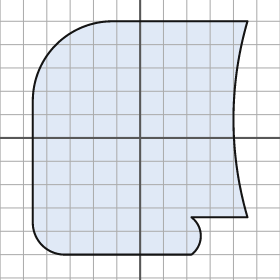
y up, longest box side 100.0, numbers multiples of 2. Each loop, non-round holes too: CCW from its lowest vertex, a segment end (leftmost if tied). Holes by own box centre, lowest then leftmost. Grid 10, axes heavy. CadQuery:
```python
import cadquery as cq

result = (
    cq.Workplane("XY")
    .moveTo(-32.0, -50.0)
    .lineTo(22.0, -50.0)
    .threePointArc((26.0, -42.0), (22.0, -34.0))
    .lineTo(46.0, -34.0)
    .threePointArc((40.0, 8.0), (46.0, 50.0))
    .lineTo(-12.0, 50.0)
    .threePointArc((-36.0, 40.0), (-46.0, 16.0))
    .lineTo(-46.0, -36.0)
    .threePointArc((-42.0, -46.0), (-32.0, -50.0))
    .close()
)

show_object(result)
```